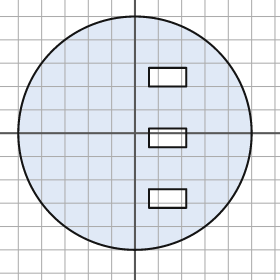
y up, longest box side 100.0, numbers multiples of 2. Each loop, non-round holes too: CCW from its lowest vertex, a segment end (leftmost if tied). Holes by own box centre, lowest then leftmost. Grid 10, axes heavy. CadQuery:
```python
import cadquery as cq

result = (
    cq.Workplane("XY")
    .moveTo(0.0, 0.0)
    .circle(50.0)
    .moveTo(6.0, -32.0)
    .lineTo(22.0, -32.0)
    .lineTo(22.0, -24.0)
    .lineTo(6.0, -24.0)
    .close()
    .moveTo(6.0, -6.0)
    .lineTo(22.0, -6.0)
    .lineTo(22.0, 2.0)
    .lineTo(6.0, 2.0)
    .close()
    .moveTo(6.0, 20.0)
    .lineTo(22.0, 20.0)
    .lineTo(22.0, 28.0)
    .lineTo(6.0, 28.0)
    .close()
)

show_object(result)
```